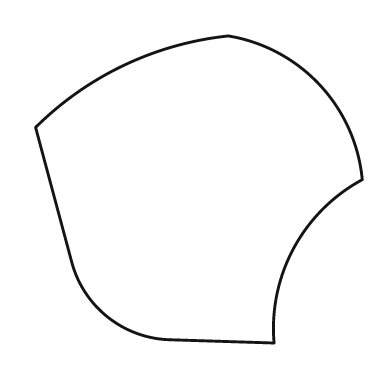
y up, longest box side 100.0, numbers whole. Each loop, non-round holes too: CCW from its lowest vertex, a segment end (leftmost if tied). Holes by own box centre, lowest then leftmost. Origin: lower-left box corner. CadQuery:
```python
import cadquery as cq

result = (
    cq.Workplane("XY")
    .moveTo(73.0, 0.0)
    .threePointArc((79.0, 29.0), (100.0, 50.0))
    .threePointArc((87.0, 79.0), (59.0, 94.0))
    .threePointArc((27.0, 85.0), (0.0, 66.0))
    .lineTo(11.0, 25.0)
    .threePointArc((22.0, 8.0), (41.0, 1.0))
    .close()
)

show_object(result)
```